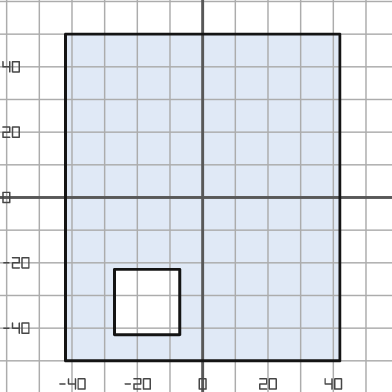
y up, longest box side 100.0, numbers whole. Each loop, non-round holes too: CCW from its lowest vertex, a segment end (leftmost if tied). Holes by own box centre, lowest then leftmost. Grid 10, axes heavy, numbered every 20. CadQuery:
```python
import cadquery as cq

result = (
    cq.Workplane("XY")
    .moveTo(-42.0, -50.0)
    .lineTo(42.0, -50.0)
    .lineTo(42.0, 50.0)
    .lineTo(-42.0, 50.0)
    .close()
    .moveTo(-27.0, -42.0)
    .lineTo(-7.0, -42.0)
    .lineTo(-7.0, -22.0)
    .lineTo(-27.0, -22.0)
    .close()
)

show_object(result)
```